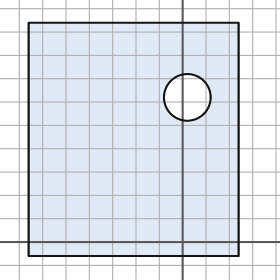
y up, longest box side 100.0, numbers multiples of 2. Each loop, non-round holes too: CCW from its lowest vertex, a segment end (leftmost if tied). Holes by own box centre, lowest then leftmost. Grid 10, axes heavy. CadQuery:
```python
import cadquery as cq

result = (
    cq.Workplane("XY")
    .moveTo(-66.0, -6.0)
    .lineTo(24.0, -6.0)
    .lineTo(24.0, 94.0)
    .lineTo(-66.0, 94.0)
    .close()
    .moveTo(2.0, 62.0)
    .circle(10.0)
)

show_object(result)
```